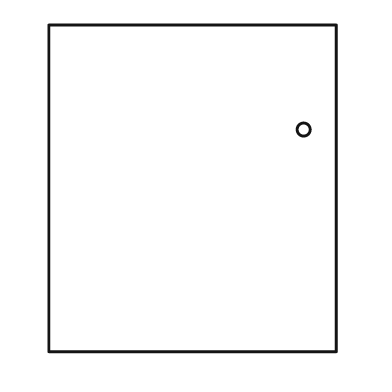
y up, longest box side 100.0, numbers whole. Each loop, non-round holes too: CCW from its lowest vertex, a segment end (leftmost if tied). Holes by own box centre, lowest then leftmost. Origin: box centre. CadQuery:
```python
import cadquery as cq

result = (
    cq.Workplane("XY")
    .moveTo(-44.0, -50.0)
    .lineTo(44.0, -50.0)
    .lineTo(44.0, 50.0)
    .lineTo(-44.0, 50.0)
    .close()
    .moveTo(34.0, 18.0)
    .circle(2.0)
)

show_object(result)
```